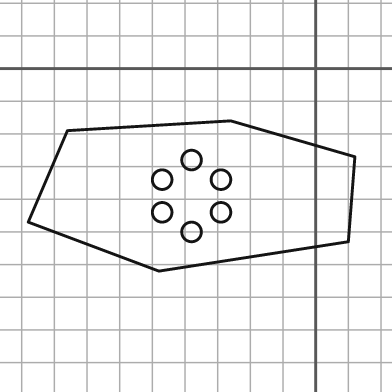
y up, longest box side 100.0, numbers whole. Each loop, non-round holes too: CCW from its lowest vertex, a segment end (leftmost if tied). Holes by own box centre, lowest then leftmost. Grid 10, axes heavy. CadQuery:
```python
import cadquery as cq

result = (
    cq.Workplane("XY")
    .moveTo(-48.0, -62.0)
    .lineTo(10.0, -53.0)
    .lineTo(12.0, -27.0)
    .lineTo(-26.0, -16.0)
    .lineTo(-76.0, -19.0)
    .lineTo(-88.0, -47.0)
    .close()
    .moveTo(-38.0, -50.0)
    .circle(3.0)
    .moveTo(-47.0, -44.0)
    .circle(3.0)
    .moveTo(-29.0, -44.0)
    .circle(3.0)
    .moveTo(-47.0, -34.0)
    .circle(3.0)
    .moveTo(-29.0, -34.0)
    .circle(3.0)
    .moveTo(-38.0, -28.0)
    .circle(3.0)
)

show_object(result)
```